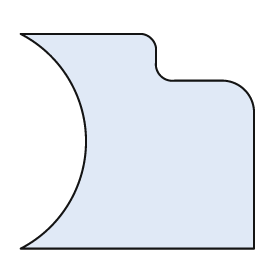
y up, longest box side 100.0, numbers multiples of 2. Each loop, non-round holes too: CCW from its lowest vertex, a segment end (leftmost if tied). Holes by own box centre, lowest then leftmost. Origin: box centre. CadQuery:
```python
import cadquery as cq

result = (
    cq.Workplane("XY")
    .moveTo(-50.0, -46.0)
    .lineTo(50.0, -46.0)
    .lineTo(50.0, 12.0)
    .threePointArc((46.0, 22.0), (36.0, 26.0))
    .lineTo(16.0, 26.0)
    .threePointArc((10.0, 28.0), (8.0, 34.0))
    .lineTo(8.0, 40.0)
    .threePointArc((6.0, 44.0), (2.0, 46.0))
    .lineTo(-50.0, 46.0)
    .threePointArc((-22.0, 0.0), (-50.0, -46.0))
    .close()
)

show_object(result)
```